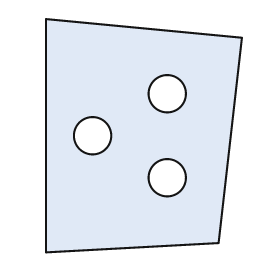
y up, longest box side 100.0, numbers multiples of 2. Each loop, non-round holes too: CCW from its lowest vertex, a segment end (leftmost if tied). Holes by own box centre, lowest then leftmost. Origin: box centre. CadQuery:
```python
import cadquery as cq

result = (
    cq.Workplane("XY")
    .moveTo(-42.0, -50.0)
    .lineTo(32.0, -46.0)
    .lineTo(42.0, 42.0)
    .lineTo(-42.0, 50.0)
    .close()
    .moveTo(10.0, -18.0)
    .circle(8.0)
    .moveTo(-22.0, 0.0)
    .circle(8.0)
    .moveTo(10.0, 18.0)
    .circle(8.0)
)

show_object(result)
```